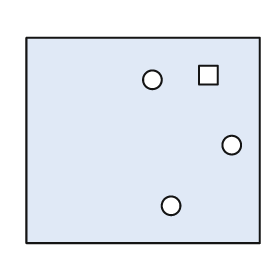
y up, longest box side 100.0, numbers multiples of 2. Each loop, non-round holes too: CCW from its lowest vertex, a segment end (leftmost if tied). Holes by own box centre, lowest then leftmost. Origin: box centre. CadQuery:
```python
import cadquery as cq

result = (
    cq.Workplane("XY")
    .moveTo(-50.0, -44.0)
    .lineTo(50.0, -44.0)
    .lineTo(50.0, 44.0)
    .lineTo(-50.0, 44.0)
    .close()
    .moveTo(12.0, -28.0)
    .circle(4.0)
    .moveTo(38.0, -2.0)
    .circle(4.0)
    .moveTo(4.0, 26.0)
    .circle(4.0)
    .moveTo(24.0, 24.0)
    .lineTo(32.0, 24.0)
    .lineTo(32.0, 32.0)
    .lineTo(24.0, 32.0)
    .close()
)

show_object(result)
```